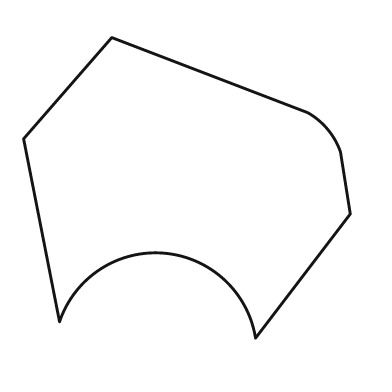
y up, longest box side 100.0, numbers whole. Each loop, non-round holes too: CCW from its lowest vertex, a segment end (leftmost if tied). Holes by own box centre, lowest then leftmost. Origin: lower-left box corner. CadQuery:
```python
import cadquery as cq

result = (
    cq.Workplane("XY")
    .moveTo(71.0, 0.0)
    .lineTo(100.0, 38.0)
    .lineTo(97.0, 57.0)
    .threePointArc((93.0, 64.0), (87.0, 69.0))
    .lineTo(27.0, 92.0)
    .lineTo(0.0, 61.0)
    .lineTo(11.0, 5.0)
    .threePointArc((43.0, 26.0), (71.0, 0.0))
    .close()
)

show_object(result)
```